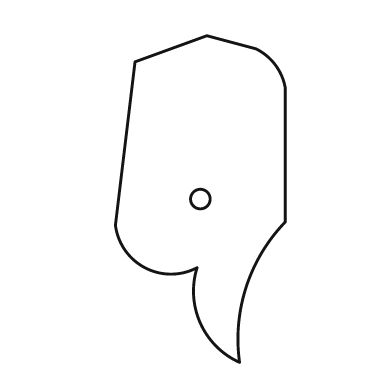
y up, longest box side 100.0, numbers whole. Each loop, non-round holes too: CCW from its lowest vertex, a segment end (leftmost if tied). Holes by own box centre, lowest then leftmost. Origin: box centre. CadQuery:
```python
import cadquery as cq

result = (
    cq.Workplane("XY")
    .moveTo(12.0, -50.0)
    .threePointArc((14.0, -27.0), (26.0, -7.0))
    .lineTo(26.0, 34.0)
    .threePointArc((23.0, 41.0), (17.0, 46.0))
    .lineTo(2.0, 50.0)
    .lineTo(-20.0, 42.0)
    .lineTo(-26.0, -8.0)
    .threePointArc((-17.0, -21.0), (-1.0, -21.0))
    .threePointArc((0.0, -38.0), (12.0, -50.0))
    .close()
    .moveTo(0.0, 0.0)
    .circle(3.0)
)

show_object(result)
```